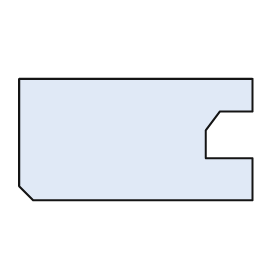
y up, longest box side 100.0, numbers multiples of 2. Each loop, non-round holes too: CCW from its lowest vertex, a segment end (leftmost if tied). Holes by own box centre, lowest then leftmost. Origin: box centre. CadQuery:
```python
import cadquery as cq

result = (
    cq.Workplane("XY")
    .moveTo(-44.0, -26.0)
    .lineTo(50.0, -26.0)
    .lineTo(50.0, -8.0)
    .lineTo(30.0, -8.0)
    .lineTo(30.0, 4.0)
    .lineTo(36.0, 12.0)
    .lineTo(50.0, 12.0)
    .lineTo(50.0, 26.0)
    .lineTo(-50.0, 26.0)
    .lineTo(-50.0, -20.0)
    .close()
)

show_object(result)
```